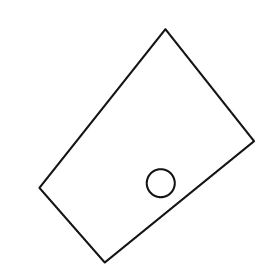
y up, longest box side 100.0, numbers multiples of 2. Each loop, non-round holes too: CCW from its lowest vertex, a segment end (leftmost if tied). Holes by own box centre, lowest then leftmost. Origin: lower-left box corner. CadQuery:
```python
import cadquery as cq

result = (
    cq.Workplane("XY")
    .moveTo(28.0, 0.0)
    .lineTo(92.0, 52.0)
    .lineTo(54.0, 100.0)
    .lineTo(0.0, 32.0)
    .close()
    .moveTo(52.0, 34.0)
    .circle(6.0)
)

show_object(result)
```